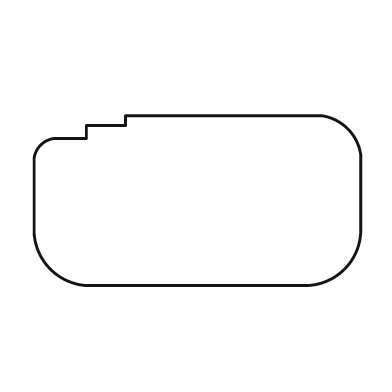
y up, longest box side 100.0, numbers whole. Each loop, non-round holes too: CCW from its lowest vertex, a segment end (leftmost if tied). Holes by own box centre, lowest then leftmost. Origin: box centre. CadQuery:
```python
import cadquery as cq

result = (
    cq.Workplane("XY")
    .moveTo(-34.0, -26.0)
    .lineTo(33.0, -26.0)
    .threePointArc((45.0, -21.0), (50.0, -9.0))
    .lineTo(50.0, 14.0)
    .threePointArc((46.0, 22.0), (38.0, 26.0))
    .lineTo(-22.0, 26.0)
    .lineTo(-22.0, 23.0)
    .lineTo(-34.0, 23.0)
    .lineTo(-34.0, 19.0)
    .lineTo(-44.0, 19.0)
    .threePointArc((-48.0, 17.0), (-50.0, 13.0))
    .lineTo(-50.0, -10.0)
    .threePointArc((-45.0, -21.0), (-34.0, -26.0))
    .close()
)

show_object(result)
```